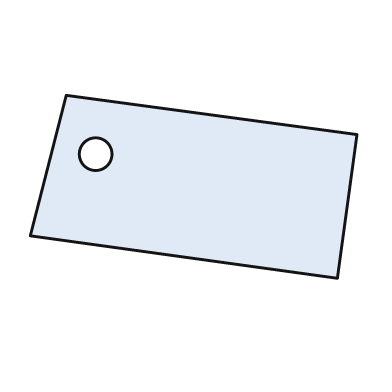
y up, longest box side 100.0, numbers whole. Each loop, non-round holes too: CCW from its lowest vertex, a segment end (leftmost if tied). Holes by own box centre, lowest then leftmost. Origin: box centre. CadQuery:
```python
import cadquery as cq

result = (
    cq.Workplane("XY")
    .moveTo(44.0, -28.0)
    .lineTo(50.0, 16.0)
    .lineTo(-39.0, 28.0)
    .lineTo(-50.0, -15.0)
    .close()
    .moveTo(-30.0, 10.0)
    .circle(5.0)
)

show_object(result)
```